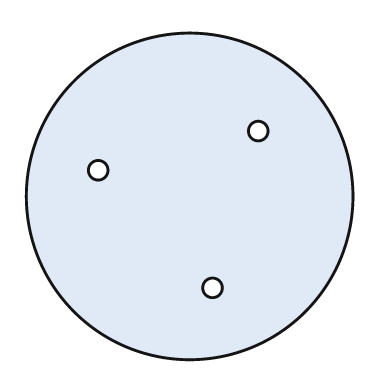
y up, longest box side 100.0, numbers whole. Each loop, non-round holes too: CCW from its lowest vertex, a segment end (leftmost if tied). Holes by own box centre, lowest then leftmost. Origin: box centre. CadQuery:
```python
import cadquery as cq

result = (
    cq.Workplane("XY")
    .moveTo(0.0, 0.0)
    .circle(50.0)
    .moveTo(7.0, -28.0)
    .circle(3.0)
    .moveTo(-28.0, 8.0)
    .circle(3.0)
    .moveTo(21.0, 20.0)
    .circle(3.0)
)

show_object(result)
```